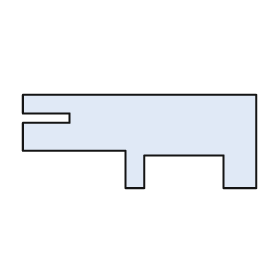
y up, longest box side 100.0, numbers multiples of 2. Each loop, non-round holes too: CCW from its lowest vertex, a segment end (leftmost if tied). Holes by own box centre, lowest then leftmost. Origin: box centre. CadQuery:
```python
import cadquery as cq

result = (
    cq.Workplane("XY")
    .moveTo(-6.0, -20.0)
    .lineTo(2.0, -20.0)
    .lineTo(2.0, -6.0)
    .lineTo(36.0, -6.0)
    .lineTo(36.0, -20.0)
    .lineTo(50.0, -20.0)
    .lineTo(50.0, 20.0)
    .lineTo(-50.0, 20.0)
    .lineTo(-50.0, 12.0)
    .lineTo(-30.0, 12.0)
    .lineTo(-30.0, 8.0)
    .lineTo(-50.0, 8.0)
    .lineTo(-50.0, -4.0)
    .lineTo(-6.0, -4.0)
    .close()
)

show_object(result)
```